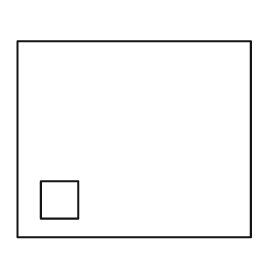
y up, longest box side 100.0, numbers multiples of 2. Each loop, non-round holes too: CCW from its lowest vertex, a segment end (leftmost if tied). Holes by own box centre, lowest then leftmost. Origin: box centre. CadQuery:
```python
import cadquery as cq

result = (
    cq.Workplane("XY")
    .moveTo(-50.0, -42.0)
    .lineTo(50.0, -42.0)
    .lineTo(50.0, 42.0)
    .lineTo(-50.0, 42.0)
    .close()
    .moveTo(-40.0, -34.0)
    .lineTo(-24.0, -34.0)
    .lineTo(-24.0, -18.0)
    .lineTo(-40.0, -18.0)
    .close()
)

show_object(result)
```